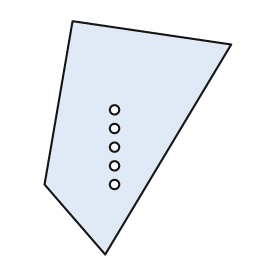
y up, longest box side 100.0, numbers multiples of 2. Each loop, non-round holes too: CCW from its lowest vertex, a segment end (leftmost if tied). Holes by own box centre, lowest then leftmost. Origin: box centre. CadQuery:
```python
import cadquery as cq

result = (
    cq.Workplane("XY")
    .moveTo(-14.0, -50.0)
    .lineTo(40.0, 40.0)
    .lineTo(-28.0, 50.0)
    .lineTo(-40.0, -20.0)
    .close()
    .moveTo(-10.0, -20.0)
    .circle(2.0)
    .moveTo(-10.0, -12.0)
    .circle(2.0)
    .moveTo(-10.0, -4.0)
    .circle(2.0)
    .moveTo(-10.0, 4.0)
    .circle(2.0)
    .moveTo(-10.0, 12.0)
    .circle(2.0)
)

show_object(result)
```